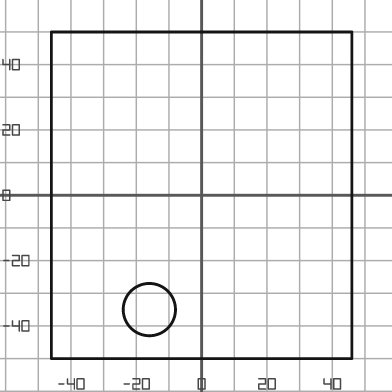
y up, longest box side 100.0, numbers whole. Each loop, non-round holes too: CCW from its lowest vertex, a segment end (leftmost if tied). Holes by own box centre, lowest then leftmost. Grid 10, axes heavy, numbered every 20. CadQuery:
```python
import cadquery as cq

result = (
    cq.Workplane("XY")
    .moveTo(-46.0, -50.0)
    .lineTo(46.0, -50.0)
    .lineTo(46.0, 50.0)
    .lineTo(-46.0, 50.0)
    .close()
    .moveTo(-16.0, -35.0)
    .circle(8.0)
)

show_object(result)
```